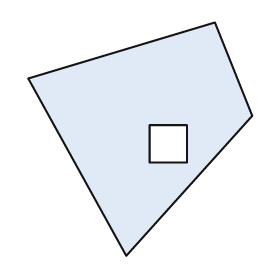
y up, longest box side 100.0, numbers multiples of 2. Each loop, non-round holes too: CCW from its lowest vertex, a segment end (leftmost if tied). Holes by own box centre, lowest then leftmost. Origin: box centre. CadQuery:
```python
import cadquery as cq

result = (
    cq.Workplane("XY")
    .moveTo(-6.0, -50.0)
    .lineTo(48.0, 10.0)
    .lineTo(32.0, 50.0)
    .lineTo(-48.0, 26.0)
    .close()
    .moveTo(4.0, -10.0)
    .lineTo(20.0, -10.0)
    .lineTo(20.0, 6.0)
    .lineTo(4.0, 6.0)
    .close()
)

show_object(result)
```